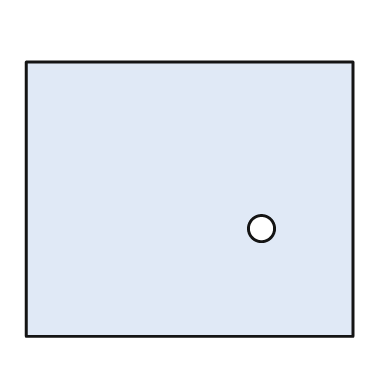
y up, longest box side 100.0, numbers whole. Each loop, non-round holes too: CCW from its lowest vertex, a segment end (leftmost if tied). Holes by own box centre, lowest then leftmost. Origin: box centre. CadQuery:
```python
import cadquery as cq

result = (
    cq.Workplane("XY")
    .moveTo(-50.0, -42.0)
    .lineTo(50.0, -42.0)
    .lineTo(50.0, 42.0)
    .lineTo(-50.0, 42.0)
    .close()
    .moveTo(22.0, -9.0)
    .circle(4.0)
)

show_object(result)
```